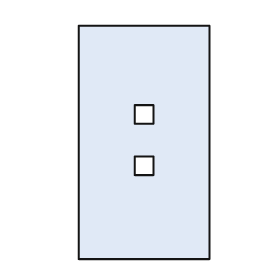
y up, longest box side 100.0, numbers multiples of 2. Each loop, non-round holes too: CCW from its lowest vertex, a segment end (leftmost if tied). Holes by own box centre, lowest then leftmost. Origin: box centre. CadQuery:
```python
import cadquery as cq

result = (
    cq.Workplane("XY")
    .moveTo(-28.0, -50.0)
    .lineTo(28.0, -50.0)
    .lineTo(28.0, 50.0)
    .lineTo(-28.0, 50.0)
    .close()
    .moveTo(-4.0, -14.0)
    .lineTo(4.0, -14.0)
    .lineTo(4.0, -6.0)
    .lineTo(-4.0, -6.0)
    .close()
    .moveTo(-4.0, 8.0)
    .lineTo(4.0, 8.0)
    .lineTo(4.0, 16.0)
    .lineTo(-4.0, 16.0)
    .close()
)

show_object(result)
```